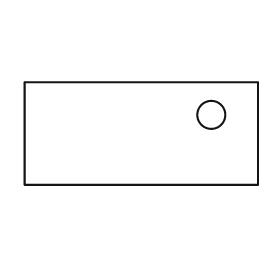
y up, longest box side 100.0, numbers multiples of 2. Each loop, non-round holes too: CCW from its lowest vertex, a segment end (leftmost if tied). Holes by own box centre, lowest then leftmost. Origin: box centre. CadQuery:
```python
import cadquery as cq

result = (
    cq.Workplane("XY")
    .moveTo(-50.0, -22.0)
    .lineTo(50.0, -22.0)
    .lineTo(50.0, 22.0)
    .lineTo(-50.0, 22.0)
    .close()
    .moveTo(30.0, 8.0)
    .circle(6.0)
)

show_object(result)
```